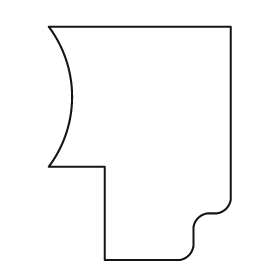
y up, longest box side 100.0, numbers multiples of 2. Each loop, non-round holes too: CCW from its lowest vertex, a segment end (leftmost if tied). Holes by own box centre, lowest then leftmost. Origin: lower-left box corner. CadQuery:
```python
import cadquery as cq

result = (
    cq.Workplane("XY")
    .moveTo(24.0, 0.0)
    .lineTo(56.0, 0.0)
    .threePointArc((60.0, 2.0), (62.0, 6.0))
    .lineTo(62.0, 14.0)
    .threePointArc((64.0, 18.0), (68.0, 20.0))
    .lineTo(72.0, 20.0)
    .threePointArc((76.0, 22.0), (78.0, 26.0))
    .lineTo(78.0, 100.0)
    .lineTo(0.0, 100.0)
    .threePointArc((10.0, 70.0), (0.0, 40.0))
    .lineTo(24.0, 40.0)
    .close()
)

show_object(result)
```